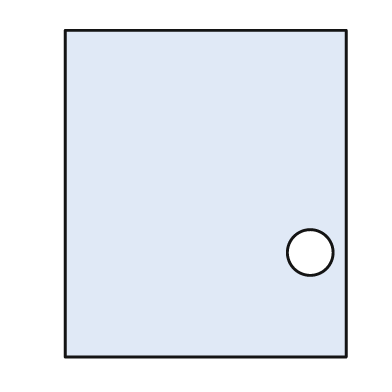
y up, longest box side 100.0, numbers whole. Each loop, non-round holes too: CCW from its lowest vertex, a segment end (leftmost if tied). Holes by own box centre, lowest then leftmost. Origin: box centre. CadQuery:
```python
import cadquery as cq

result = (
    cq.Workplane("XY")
    .moveTo(-43.0, -50.0)
    .lineTo(43.0, -50.0)
    .lineTo(43.0, 50.0)
    .lineTo(-43.0, 50.0)
    .close()
    .moveTo(32.0, -18.0)
    .circle(7.0)
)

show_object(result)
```